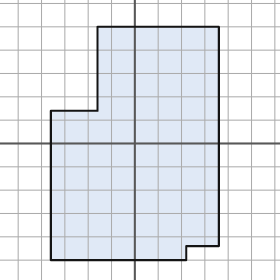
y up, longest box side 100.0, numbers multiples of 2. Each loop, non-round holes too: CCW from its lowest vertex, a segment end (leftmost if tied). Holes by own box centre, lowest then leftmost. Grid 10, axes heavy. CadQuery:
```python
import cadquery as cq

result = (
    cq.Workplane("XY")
    .moveTo(-36.0, -50.0)
    .lineTo(22.0, -50.0)
    .lineTo(22.0, -44.0)
    .lineTo(36.0, -44.0)
    .lineTo(36.0, 50.0)
    .lineTo(-16.0, 50.0)
    .lineTo(-16.0, 14.0)
    .lineTo(-36.0, 14.0)
    .close()
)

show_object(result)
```